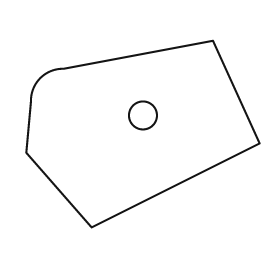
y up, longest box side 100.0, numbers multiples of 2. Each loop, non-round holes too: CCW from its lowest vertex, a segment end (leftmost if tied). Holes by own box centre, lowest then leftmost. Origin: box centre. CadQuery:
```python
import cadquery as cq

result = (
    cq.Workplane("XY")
    .moveTo(-22.0, -40.0)
    .lineTo(50.0, -4.0)
    .lineTo(30.0, 40.0)
    .lineTo(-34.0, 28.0)
    .threePointArc((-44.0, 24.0), (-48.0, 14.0))
    .lineTo(-50.0, -8.0)
    .close()
    .moveTo(0.0, 8.0)
    .circle(6.0)
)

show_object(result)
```